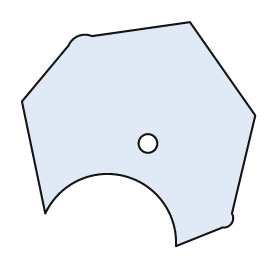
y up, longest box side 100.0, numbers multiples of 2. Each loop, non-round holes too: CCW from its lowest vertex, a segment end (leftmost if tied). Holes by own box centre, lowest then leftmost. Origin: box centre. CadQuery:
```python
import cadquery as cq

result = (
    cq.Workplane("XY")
    .moveTo(16.0, -48.0)
    .lineTo(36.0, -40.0)
    .threePointArc((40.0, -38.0), (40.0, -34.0))
    .lineTo(50.0, 8.0)
    .lineTo(22.0, 48.0)
    .lineTo(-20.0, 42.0)
    .threePointArc((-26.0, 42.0), (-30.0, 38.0))
    .lineTo(-50.0, 14.0)
    .lineTo(-40.0, -34.0)
    .threePointArc((-6.0, -18.0), (16.0, -48.0))
    .close()
    .moveTo(4.0, -4.0)
    .circle(4.0)
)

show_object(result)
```